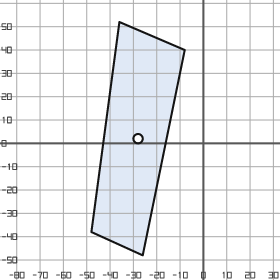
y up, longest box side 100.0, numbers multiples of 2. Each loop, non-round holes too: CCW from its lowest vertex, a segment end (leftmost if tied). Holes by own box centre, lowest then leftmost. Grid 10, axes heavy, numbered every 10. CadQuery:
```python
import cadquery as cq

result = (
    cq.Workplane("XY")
    .moveTo(-26.0, -48.0)
    .lineTo(-8.0, 40.0)
    .lineTo(-36.0, 52.0)
    .lineTo(-48.0, -38.0)
    .close()
    .moveTo(-28.0, 2.0)
    .circle(2.0)
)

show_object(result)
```